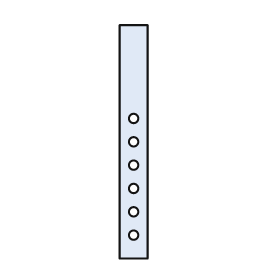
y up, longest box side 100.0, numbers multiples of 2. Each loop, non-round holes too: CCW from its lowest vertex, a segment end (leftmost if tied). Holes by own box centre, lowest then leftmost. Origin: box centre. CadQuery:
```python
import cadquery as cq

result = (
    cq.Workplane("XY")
    .moveTo(-6.0, -50.0)
    .lineTo(6.0, -50.0)
    .lineTo(6.0, 50.0)
    .lineTo(-6.0, 50.0)
    .close()
    .moveTo(0.0, -40.0)
    .circle(2.0)
    .moveTo(0.0, -30.0)
    .circle(2.0)
    .moveTo(0.0, -20.0)
    .circle(2.0)
    .moveTo(0.0, -10.0)
    .circle(2.0)
    .moveTo(0.0, 0.0)
    .circle(2.0)
    .moveTo(0.0, 10.0)
    .circle(2.0)
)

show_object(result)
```